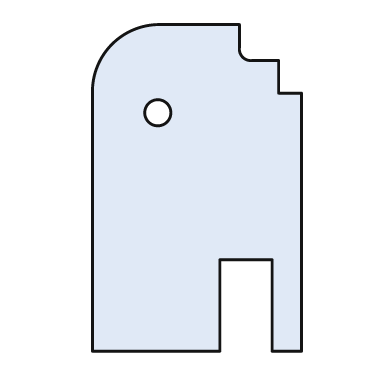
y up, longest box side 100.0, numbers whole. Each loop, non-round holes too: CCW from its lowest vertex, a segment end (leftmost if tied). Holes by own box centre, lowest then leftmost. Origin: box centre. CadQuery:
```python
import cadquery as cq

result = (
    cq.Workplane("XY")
    .moveTo(-32.0, -50.0)
    .lineTo(7.0, -50.0)
    .lineTo(7.0, -22.0)
    .lineTo(23.0, -22.0)
    .lineTo(23.0, -50.0)
    .lineTo(32.0, -50.0)
    .lineTo(32.0, 29.0)
    .lineTo(25.0, 29.0)
    .lineTo(25.0, 39.0)
    .lineTo(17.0, 39.0)
    .threePointArc((14.0, 40.0), (13.0, 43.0))
    .lineTo(13.0, 50.0)
    .lineTo(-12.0, 50.0)
    .threePointArc((-26.0, 44.0), (-32.0, 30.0))
    .close()
    .moveTo(-12.0, 23.0)
    .circle(4.0)
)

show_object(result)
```